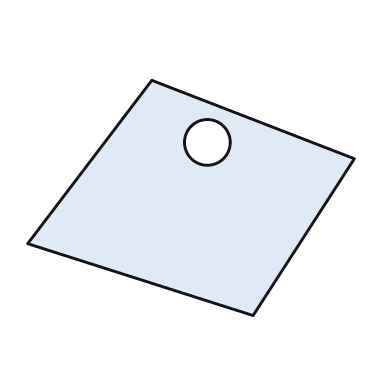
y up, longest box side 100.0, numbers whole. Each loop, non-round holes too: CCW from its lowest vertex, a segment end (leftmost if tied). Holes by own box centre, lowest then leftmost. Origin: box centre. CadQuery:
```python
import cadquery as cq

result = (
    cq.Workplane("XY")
    .moveTo(19.0, -36.0)
    .lineTo(50.0, 12.0)
    .lineTo(-12.0, 36.0)
    .lineTo(-50.0, -14.0)
    .close()
    .moveTo(5.0, 17.0)
    .circle(7.0)
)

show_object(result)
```